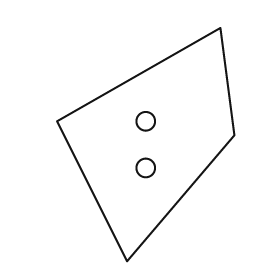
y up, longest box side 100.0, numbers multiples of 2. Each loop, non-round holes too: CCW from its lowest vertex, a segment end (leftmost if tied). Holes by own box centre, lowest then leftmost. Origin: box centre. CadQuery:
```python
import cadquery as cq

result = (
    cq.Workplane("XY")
    .moveTo(-8.0, -50.0)
    .lineTo(38.0, 4.0)
    .lineTo(32.0, 50.0)
    .lineTo(-38.0, 10.0)
    .close()
    .moveTo(0.0, -10.0)
    .circle(4.0)
    .moveTo(0.0, 10.0)
    .circle(4.0)
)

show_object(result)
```